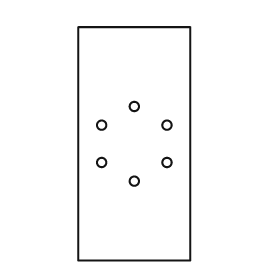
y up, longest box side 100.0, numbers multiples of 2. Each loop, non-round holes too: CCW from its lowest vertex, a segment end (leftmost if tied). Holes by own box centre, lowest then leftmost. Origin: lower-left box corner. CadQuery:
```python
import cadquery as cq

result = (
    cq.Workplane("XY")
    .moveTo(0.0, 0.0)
    .lineTo(48.0, 0.0)
    .lineTo(48.0, 100.0)
    .lineTo(0.0, 100.0)
    .close()
    .moveTo(24.0, 34.0)
    .circle(2.0)
    .moveTo(10.0, 42.0)
    .circle(2.0)
    .moveTo(38.0, 42.0)
    .circle(2.0)
    .moveTo(10.0, 58.0)
    .circle(2.0)
    .moveTo(38.0, 58.0)
    .circle(2.0)
    .moveTo(24.0, 66.0)
    .circle(2.0)
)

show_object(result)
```